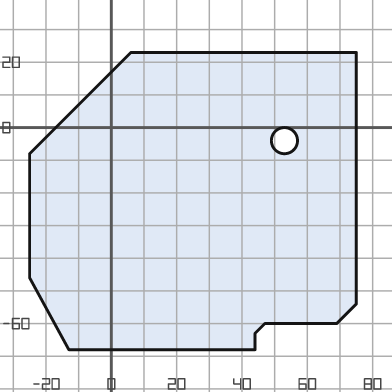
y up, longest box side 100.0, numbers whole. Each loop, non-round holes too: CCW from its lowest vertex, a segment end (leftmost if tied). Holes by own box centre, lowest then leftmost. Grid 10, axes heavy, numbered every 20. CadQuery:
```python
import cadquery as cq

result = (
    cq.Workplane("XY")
    .moveTo(-13.0, -68.0)
    .lineTo(44.0, -68.0)
    .lineTo(44.0, -63.0)
    .lineTo(47.0, -60.0)
    .lineTo(69.0, -60.0)
    .lineTo(75.0, -54.0)
    .lineTo(75.0, 23.0)
    .lineTo(6.0, 23.0)
    .lineTo(-25.0, -8.0)
    .lineTo(-25.0, -46.0)
    .close()
    .moveTo(53.0, -4.0)
    .circle(4.0)
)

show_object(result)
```